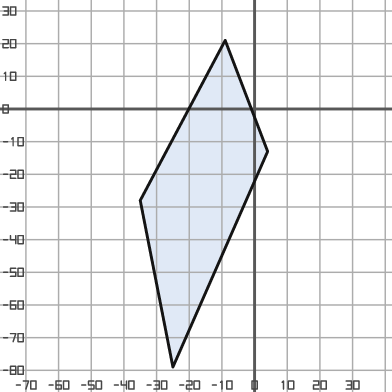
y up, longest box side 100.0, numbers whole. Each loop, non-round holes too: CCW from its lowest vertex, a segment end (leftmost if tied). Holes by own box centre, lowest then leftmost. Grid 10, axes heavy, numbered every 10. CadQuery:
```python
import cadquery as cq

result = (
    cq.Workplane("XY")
    .moveTo(-25.0, -79.0)
    .lineTo(4.0, -13.0)
    .lineTo(-9.0, 21.0)
    .lineTo(-35.0, -28.0)
    .close()
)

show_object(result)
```